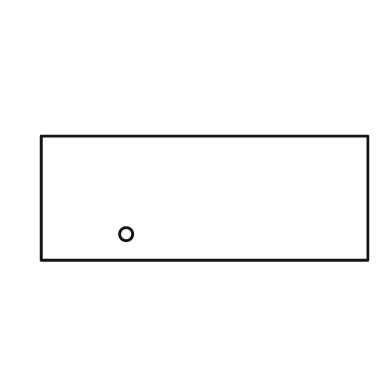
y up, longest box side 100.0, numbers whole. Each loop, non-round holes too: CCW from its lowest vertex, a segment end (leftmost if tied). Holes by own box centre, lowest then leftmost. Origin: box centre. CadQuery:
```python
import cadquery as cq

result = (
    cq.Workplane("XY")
    .moveTo(-50.0, -19.0)
    .lineTo(50.0, -19.0)
    .lineTo(50.0, 19.0)
    .lineTo(-50.0, 19.0)
    .close()
    .moveTo(-24.0, -11.0)
    .circle(2.0)
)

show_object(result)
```